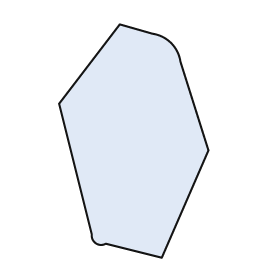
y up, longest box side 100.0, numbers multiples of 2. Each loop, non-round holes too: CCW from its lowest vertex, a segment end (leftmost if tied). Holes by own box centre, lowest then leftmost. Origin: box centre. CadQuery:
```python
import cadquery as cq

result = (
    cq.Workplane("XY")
    .moveTo(12.0, -50.0)
    .lineTo(32.0, -4.0)
    .lineTo(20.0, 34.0)
    .threePointArc((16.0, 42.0), (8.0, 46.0))
    .lineTo(-6.0, 50.0)
    .lineTo(-32.0, 16.0)
    .lineTo(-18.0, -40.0)
    .threePointArc((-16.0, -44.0), (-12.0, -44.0))
    .close()
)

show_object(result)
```